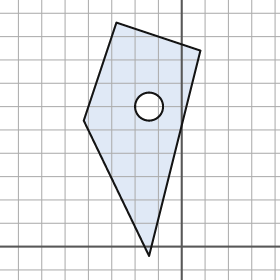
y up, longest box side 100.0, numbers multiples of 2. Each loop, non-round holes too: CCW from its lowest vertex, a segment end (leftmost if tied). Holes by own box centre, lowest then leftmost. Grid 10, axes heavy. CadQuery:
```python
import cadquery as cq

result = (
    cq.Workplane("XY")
    .moveTo(-14.0, -4.0)
    .lineTo(8.0, 84.0)
    .lineTo(-28.0, 96.0)
    .lineTo(-42.0, 54.0)
    .close()
    .moveTo(-14.0, 60.0)
    .circle(6.0)
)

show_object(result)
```